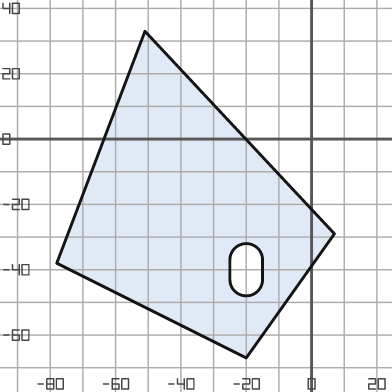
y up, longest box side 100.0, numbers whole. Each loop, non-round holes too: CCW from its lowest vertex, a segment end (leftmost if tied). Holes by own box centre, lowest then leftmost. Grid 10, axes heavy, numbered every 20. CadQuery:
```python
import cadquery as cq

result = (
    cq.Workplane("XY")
    .moveTo(-20.0, -67.0)
    .lineTo(7.0, -29.0)
    .lineTo(-51.0, 33.0)
    .lineTo(-78.0, -38.0)
    .close()
    .moveTo(-25.0, -43.0)
    .threePointArc((-20.0, -48.0), (-15.0, -43.0))
    .lineTo(-15.0, -37.0)
    .threePointArc((-20.0, -32.0), (-25.0, -37.0))
    .close()
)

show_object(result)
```